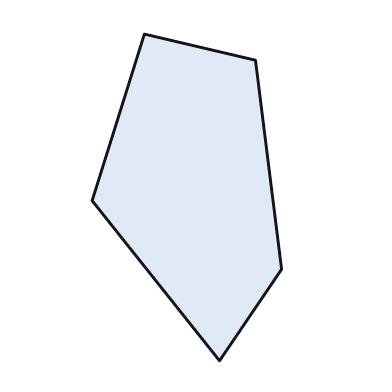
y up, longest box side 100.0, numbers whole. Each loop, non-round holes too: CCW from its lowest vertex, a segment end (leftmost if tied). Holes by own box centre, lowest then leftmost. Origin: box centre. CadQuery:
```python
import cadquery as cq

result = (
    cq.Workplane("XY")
    .moveTo(10.0, -50.0)
    .lineTo(29.0, -22.0)
    .lineTo(21.0, 42.0)
    .lineTo(-13.0, 50.0)
    .lineTo(-29.0, -1.0)
    .close()
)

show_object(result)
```